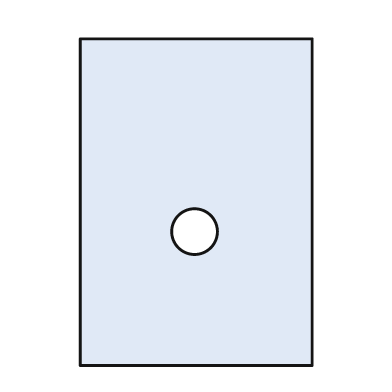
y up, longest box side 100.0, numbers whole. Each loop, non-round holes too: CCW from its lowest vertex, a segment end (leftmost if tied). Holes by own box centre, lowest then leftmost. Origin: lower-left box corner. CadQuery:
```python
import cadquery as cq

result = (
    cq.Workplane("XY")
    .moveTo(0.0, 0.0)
    .lineTo(71.0, 0.0)
    .lineTo(71.0, 100.0)
    .lineTo(0.0, 100.0)
    .close()
    .moveTo(35.0, 41.0)
    .circle(7.0)
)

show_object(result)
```